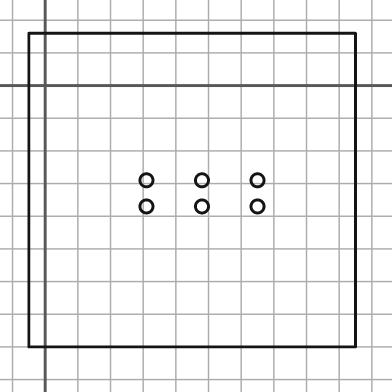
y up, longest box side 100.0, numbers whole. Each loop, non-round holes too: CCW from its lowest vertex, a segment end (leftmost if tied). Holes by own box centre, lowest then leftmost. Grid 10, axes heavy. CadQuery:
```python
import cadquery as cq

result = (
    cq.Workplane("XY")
    .moveTo(-5.0, -80.0)
    .lineTo(95.0, -80.0)
    .lineTo(95.0, 16.0)
    .lineTo(-5.0, 16.0)
    .close()
    .moveTo(31.0, -37.0)
    .circle(2.0)
    .moveTo(48.0, -37.0)
    .circle(2.0)
    .moveTo(65.0, -37.0)
    .circle(2.0)
    .moveTo(31.0, -29.0)
    .circle(2.0)
    .moveTo(48.0, -29.0)
    .circle(2.0)
    .moveTo(65.0, -29.0)
    .circle(2.0)
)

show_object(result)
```